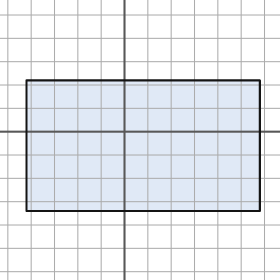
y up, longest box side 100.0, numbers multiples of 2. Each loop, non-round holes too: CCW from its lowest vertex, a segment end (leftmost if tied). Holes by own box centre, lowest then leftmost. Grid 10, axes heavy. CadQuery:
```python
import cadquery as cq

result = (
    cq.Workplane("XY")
    .moveTo(-42.0, -34.0)
    .lineTo(58.0, -34.0)
    .lineTo(58.0, 22.0)
    .lineTo(-42.0, 22.0)
    .close()
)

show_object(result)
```